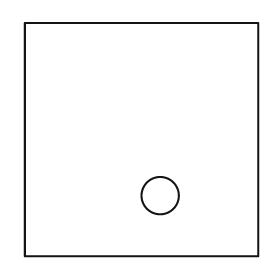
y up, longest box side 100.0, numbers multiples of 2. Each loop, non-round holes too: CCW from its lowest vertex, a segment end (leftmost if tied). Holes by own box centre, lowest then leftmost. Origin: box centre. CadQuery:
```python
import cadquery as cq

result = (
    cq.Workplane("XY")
    .moveTo(-50.0, -50.0)
    .lineTo(50.0, -50.0)
    .lineTo(50.0, 50.0)
    .lineTo(-50.0, 50.0)
    .close()
    .moveTo(8.0, -24.0)
    .circle(8.0)
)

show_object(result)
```